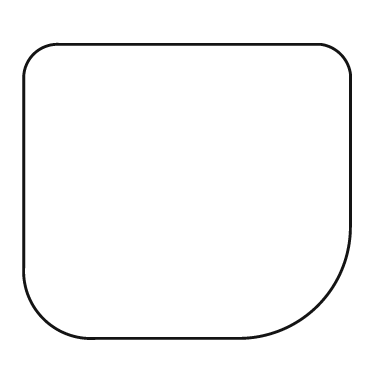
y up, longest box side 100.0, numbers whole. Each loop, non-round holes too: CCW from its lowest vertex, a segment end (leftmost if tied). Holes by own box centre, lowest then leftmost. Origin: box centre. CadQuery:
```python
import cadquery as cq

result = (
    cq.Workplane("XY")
    .moveTo(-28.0, -45.0)
    .lineTo(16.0, -45.0)
    .threePointArc((40.0, -35.0), (50.0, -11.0))
    .lineTo(50.0, 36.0)
    .threePointArc((47.0, 42.0), (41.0, 45.0))
    .lineTo(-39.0, 45.0)
    .threePointArc((-47.0, 42.0), (-50.0, 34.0))
    .lineTo(-50.0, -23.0)
    .threePointArc((-44.0, -39.0), (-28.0, -45.0))
    .close()
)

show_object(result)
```